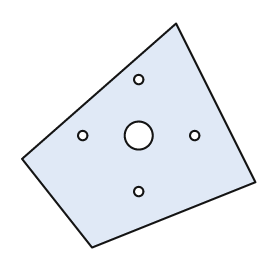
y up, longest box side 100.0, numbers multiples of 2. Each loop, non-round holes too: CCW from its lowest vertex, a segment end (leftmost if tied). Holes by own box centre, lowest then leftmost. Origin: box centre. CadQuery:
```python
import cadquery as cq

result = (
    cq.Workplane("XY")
    .moveTo(-20.0, -48.0)
    .lineTo(50.0, -20.0)
    .lineTo(16.0, 48.0)
    .lineTo(-50.0, -10.0)
    .close()
    .moveTo(0.0, -24.0)
    .circle(2.0)
    .moveTo(-24.0, 0.0)
    .circle(2.0)
    .moveTo(0.0, 0.0)
    .circle(6.0)
    .moveTo(24.0, 0.0)
    .circle(2.0)
    .moveTo(0.0, 24.0)
    .circle(2.0)
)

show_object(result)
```